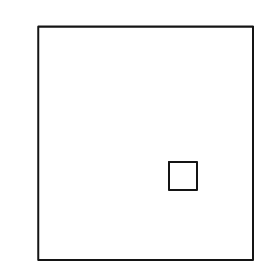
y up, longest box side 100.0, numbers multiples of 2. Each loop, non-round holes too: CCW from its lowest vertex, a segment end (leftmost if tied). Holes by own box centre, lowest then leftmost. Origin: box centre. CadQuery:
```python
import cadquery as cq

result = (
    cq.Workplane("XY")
    .moveTo(-46.0, -50.0)
    .lineTo(46.0, -50.0)
    .lineTo(46.0, 50.0)
    .lineTo(-46.0, 50.0)
    .close()
    .moveTo(10.0, -20.0)
    .lineTo(22.0, -20.0)
    .lineTo(22.0, -8.0)
    .lineTo(10.0, -8.0)
    .close()
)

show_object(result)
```